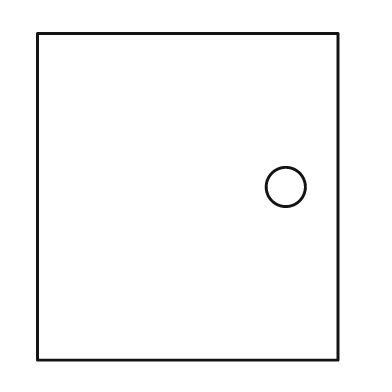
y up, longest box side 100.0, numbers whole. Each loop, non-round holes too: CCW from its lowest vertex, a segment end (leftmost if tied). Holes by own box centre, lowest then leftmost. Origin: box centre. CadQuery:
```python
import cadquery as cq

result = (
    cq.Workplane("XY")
    .moveTo(-46.0, -50.0)
    .lineTo(46.0, -50.0)
    .lineTo(46.0, 50.0)
    .lineTo(-46.0, 50.0)
    .close()
    .moveTo(30.0, 3.0)
    .circle(6.0)
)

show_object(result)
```